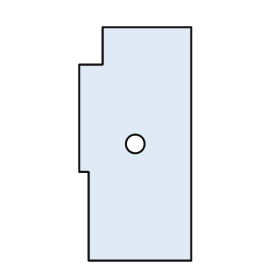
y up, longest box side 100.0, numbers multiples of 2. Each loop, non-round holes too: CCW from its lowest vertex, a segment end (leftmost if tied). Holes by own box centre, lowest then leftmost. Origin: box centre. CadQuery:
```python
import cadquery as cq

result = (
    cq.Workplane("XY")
    .moveTo(-20.0, -50.0)
    .lineTo(24.0, -50.0)
    .lineTo(24.0, 50.0)
    .lineTo(-14.0, 50.0)
    .lineTo(-14.0, 34.0)
    .lineTo(-24.0, 34.0)
    .lineTo(-24.0, -12.0)
    .lineTo(-20.0, -12.0)
    .close()
    .moveTo(0.0, 0.0)
    .circle(4.0)
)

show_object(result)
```